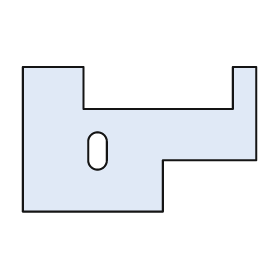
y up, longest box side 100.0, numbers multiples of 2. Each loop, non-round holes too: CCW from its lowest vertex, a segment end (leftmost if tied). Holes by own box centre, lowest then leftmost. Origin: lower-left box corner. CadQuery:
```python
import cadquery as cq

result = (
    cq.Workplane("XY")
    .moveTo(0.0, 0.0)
    .lineTo(60.0, 0.0)
    .lineTo(60.0, 22.0)
    .lineTo(100.0, 22.0)
    .lineTo(100.0, 62.0)
    .lineTo(90.0, 62.0)
    .lineTo(90.0, 44.0)
    .lineTo(26.0, 44.0)
    .lineTo(26.0, 62.0)
    .lineTo(0.0, 62.0)
    .close()
    .moveTo(28.0, 22.0)
    .threePointArc((32.0, 18.0), (36.0, 22.0))
    .lineTo(36.0, 30.0)
    .threePointArc((32.0, 34.0), (28.0, 30.0))
    .close()
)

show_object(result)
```